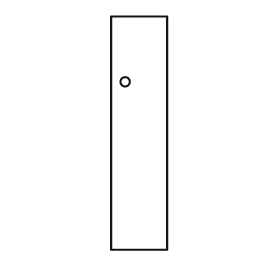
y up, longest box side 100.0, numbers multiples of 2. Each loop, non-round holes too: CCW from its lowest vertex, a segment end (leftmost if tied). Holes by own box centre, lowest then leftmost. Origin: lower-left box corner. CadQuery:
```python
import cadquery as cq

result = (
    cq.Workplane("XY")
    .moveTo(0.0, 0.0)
    .lineTo(24.0, 0.0)
    .lineTo(24.0, 100.0)
    .lineTo(0.0, 100.0)
    .close()
    .moveTo(6.0, 72.0)
    .circle(2.0)
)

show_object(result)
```